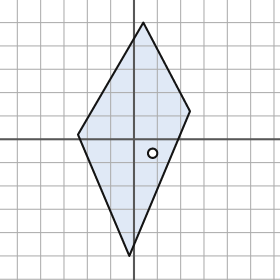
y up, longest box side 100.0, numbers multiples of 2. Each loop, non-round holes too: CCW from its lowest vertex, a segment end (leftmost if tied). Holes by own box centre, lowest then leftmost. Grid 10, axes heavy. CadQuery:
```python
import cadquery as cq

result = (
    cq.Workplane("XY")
    .moveTo(-2.0, -50.0)
    .lineTo(24.0, 12.0)
    .lineTo(4.0, 50.0)
    .lineTo(-24.0, 2.0)
    .close()
    .moveTo(8.0, -6.0)
    .circle(2.0)
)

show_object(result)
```